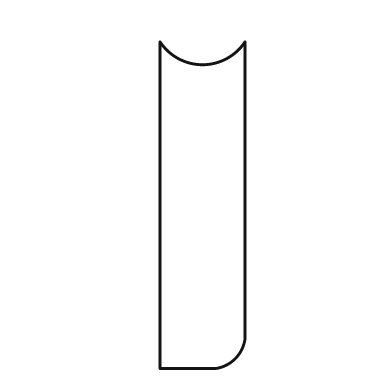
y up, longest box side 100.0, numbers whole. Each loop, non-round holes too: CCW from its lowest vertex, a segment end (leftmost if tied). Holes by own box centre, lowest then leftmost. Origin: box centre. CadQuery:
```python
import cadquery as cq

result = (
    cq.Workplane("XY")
    .moveTo(-13.0, -50.0)
    .lineTo(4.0, -50.0)
    .threePointArc((10.0, -47.0), (13.0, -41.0))
    .lineTo(13.0, 50.0)
    .threePointArc((0.0, 43.0), (-13.0, 50.0))
    .close()
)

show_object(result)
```